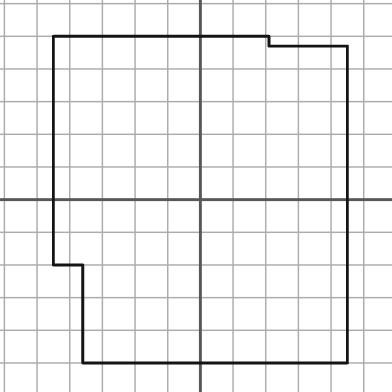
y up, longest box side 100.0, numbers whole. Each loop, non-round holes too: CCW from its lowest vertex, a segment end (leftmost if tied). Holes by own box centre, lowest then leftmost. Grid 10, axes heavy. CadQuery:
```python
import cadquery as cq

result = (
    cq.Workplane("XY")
    .moveTo(-36.0, -50.0)
    .lineTo(45.0, -50.0)
    .lineTo(45.0, 47.0)
    .lineTo(21.0, 47.0)
    .lineTo(21.0, 50.0)
    .lineTo(-45.0, 50.0)
    .lineTo(-45.0, -20.0)
    .lineTo(-36.0, -20.0)
    .close()
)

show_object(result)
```